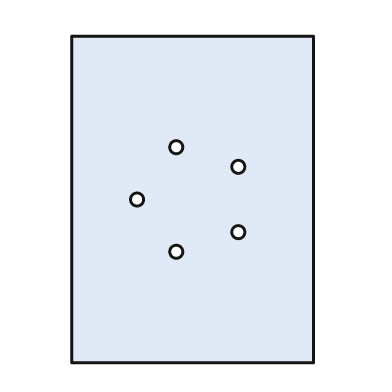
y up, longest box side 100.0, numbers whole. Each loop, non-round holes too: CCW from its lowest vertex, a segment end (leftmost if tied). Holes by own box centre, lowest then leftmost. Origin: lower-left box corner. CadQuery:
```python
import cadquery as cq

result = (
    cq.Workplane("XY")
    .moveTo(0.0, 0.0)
    .lineTo(74.0, 0.0)
    .lineTo(74.0, 100.0)
    .lineTo(0.0, 100.0)
    .close()
    .moveTo(32.0, 34.0)
    .circle(2.0)
    .moveTo(51.0, 40.0)
    .circle(2.0)
    .moveTo(20.0, 50.0)
    .circle(2.0)
    .moveTo(51.0, 60.0)
    .circle(2.0)
    .moveTo(32.0, 66.0)
    .circle(2.0)
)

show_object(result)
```